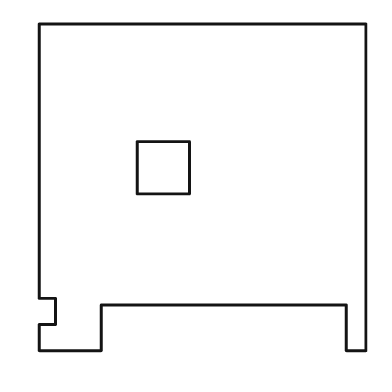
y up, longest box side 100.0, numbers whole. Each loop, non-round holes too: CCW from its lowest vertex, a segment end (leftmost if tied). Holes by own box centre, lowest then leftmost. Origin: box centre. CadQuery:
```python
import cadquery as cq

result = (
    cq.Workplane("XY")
    .moveTo(-50.0, -50.0)
    .lineTo(-31.0, -50.0)
    .lineTo(-31.0, -36.0)
    .lineTo(44.0, -36.0)
    .lineTo(44.0, -50.0)
    .lineTo(50.0, -50.0)
    .lineTo(50.0, 50.0)
    .lineTo(-50.0, 50.0)
    .lineTo(-50.0, -34.0)
    .lineTo(-45.0, -34.0)
    .lineTo(-45.0, -42.0)
    .lineTo(-50.0, -42.0)
    .close()
    .moveTo(-20.0, -2.0)
    .lineTo(-4.0, -2.0)
    .lineTo(-4.0, 14.0)
    .lineTo(-20.0, 14.0)
    .close()
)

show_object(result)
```